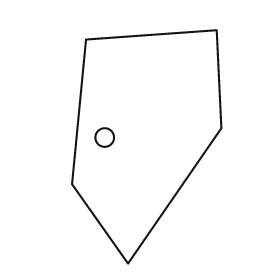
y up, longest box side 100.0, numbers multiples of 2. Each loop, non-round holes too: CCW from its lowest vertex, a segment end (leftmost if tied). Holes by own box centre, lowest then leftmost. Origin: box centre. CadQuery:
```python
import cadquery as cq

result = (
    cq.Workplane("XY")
    .moveTo(-8.0, -50.0)
    .lineTo(32.0, 8.0)
    .lineTo(30.0, 50.0)
    .lineTo(-26.0, 46.0)
    .lineTo(-32.0, -16.0)
    .close()
    .moveTo(-18.0, 4.0)
    .circle(4.0)
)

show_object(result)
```